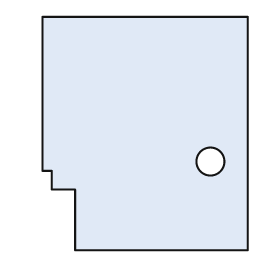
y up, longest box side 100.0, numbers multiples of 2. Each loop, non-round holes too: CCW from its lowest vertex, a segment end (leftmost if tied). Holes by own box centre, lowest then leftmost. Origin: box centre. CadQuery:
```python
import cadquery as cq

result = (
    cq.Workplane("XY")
    .moveTo(-30.0, -50.0)
    .lineTo(44.0, -50.0)
    .lineTo(44.0, 50.0)
    .lineTo(-44.0, 50.0)
    .lineTo(-44.0, -16.0)
    .lineTo(-40.0, -16.0)
    .lineTo(-40.0, -24.0)
    .lineTo(-30.0, -24.0)
    .close()
    .moveTo(28.0, -12.0)
    .circle(6.0)
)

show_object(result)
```